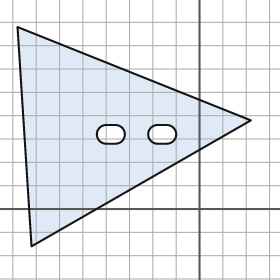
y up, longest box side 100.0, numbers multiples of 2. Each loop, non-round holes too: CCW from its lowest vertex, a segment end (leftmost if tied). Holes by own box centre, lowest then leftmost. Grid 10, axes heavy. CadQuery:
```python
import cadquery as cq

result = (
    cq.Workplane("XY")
    .moveTo(-72.0, -16.0)
    .lineTo(22.0, 38.0)
    .lineTo(-78.0, 78.0)
    .close()
    .moveTo(-40.0, 28.0)
    .lineTo(-36.0, 28.0)
    .threePointArc((-32.0, 32.0), (-36.0, 36.0))
    .lineTo(-40.0, 36.0)
    .threePointArc((-44.0, 32.0), (-40.0, 28.0))
    .close()
    .moveTo(-18.0, 28.0)
    .lineTo(-14.0, 28.0)
    .threePointArc((-10.0, 32.0), (-14.0, 36.0))
    .lineTo(-18.0, 36.0)
    .threePointArc((-22.0, 32.0), (-18.0, 28.0))
    .close()
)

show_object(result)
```